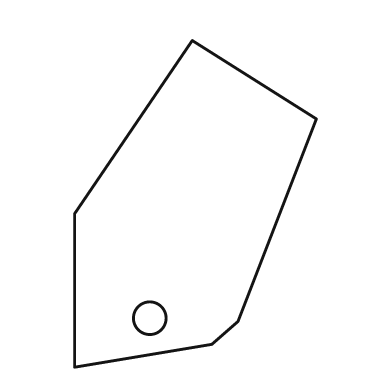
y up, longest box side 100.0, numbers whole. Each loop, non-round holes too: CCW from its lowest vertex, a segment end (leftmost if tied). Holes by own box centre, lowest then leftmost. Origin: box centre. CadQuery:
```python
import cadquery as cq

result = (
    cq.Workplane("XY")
    .moveTo(-37.0, -50.0)
    .lineTo(5.0, -43.0)
    .lineTo(13.0, -36.0)
    .lineTo(37.0, 26.0)
    .lineTo(-1.0, 50.0)
    .lineTo(-37.0, -3.0)
    .close()
    .moveTo(-14.0, -35.0)
    .circle(5.0)
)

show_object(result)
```